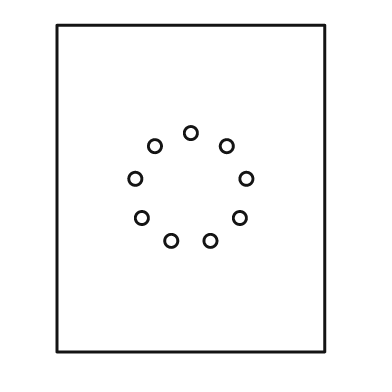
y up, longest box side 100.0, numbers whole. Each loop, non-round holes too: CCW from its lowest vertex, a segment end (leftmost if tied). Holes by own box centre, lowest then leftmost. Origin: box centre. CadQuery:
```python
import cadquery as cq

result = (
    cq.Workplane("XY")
    .moveTo(-41.0, -50.0)
    .lineTo(41.0, -50.0)
    .lineTo(41.0, 50.0)
    .lineTo(-41.0, 50.0)
    .close()
    .moveTo(-6.0, -16.0)
    .circle(2.0)
    .moveTo(6.0, -16.0)
    .circle(2.0)
    .moveTo(-15.0, -9.0)
    .circle(2.0)
    .moveTo(15.0, -9.0)
    .circle(2.0)
    .moveTo(-17.0, 3.0)
    .circle(2.0)
    .moveTo(17.0, 3.0)
    .circle(2.0)
    .moveTo(-11.0, 13.0)
    .circle(2.0)
    .moveTo(11.0, 13.0)
    .circle(2.0)
    .moveTo(0.0, 17.0)
    .circle(2.0)
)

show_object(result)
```